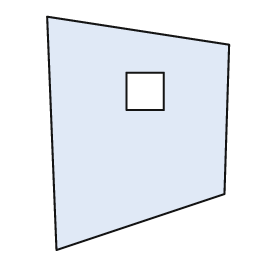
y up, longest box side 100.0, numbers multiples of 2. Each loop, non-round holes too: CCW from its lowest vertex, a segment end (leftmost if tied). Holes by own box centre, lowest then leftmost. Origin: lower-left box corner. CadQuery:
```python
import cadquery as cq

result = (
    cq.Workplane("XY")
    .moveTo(4.0, 0.0)
    .lineTo(76.0, 24.0)
    .lineTo(78.0, 88.0)
    .lineTo(0.0, 100.0)
    .close()
    .moveTo(34.0, 60.0)
    .lineTo(50.0, 60.0)
    .lineTo(50.0, 76.0)
    .lineTo(34.0, 76.0)
    .close()
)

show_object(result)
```